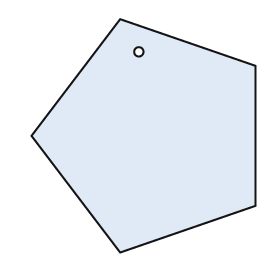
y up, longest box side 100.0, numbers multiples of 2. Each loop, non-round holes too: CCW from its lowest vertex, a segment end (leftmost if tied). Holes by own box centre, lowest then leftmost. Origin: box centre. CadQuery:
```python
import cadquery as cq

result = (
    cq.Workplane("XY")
    .moveTo(-10.0, -50.0)
    .lineTo(48.0, -30.0)
    .lineTo(48.0, 30.0)
    .lineTo(-10.0, 50.0)
    .lineTo(-48.0, 0.0)
    .close()
    .moveTo(-2.0, 36.0)
    .circle(2.0)
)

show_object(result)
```